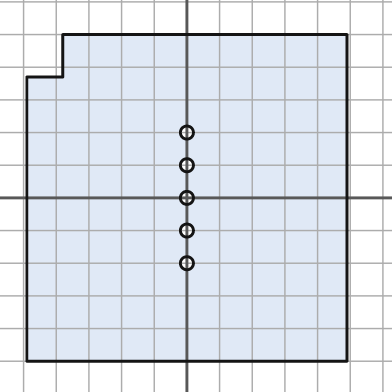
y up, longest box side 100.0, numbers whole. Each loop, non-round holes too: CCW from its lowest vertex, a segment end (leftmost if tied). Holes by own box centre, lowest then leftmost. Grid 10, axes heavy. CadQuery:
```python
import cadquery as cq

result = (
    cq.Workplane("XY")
    .moveTo(-49.0, -50.0)
    .lineTo(49.0, -50.0)
    .lineTo(49.0, 50.0)
    .lineTo(-38.0, 50.0)
    .lineTo(-38.0, 37.0)
    .lineTo(-49.0, 37.0)
    .close()
    .moveTo(0.0, -20.0)
    .circle(2.0)
    .moveTo(0.0, -10.0)
    .circle(2.0)
    .moveTo(0.0, 0.0)
    .circle(2.0)
    .moveTo(0.0, 10.0)
    .circle(2.0)
    .moveTo(0.0, 20.0)
    .circle(2.0)
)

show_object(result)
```